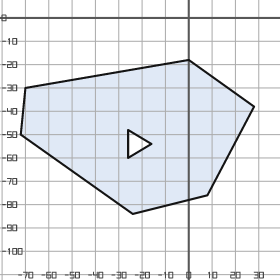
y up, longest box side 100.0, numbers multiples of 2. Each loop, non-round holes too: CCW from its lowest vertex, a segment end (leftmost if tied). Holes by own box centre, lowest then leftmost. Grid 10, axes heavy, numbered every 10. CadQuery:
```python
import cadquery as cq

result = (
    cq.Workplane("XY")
    .moveTo(-24.0, -84.0)
    .lineTo(8.0, -76.0)
    .lineTo(28.0, -38.0)
    .lineTo(0.0, -18.0)
    .lineTo(-70.0, -30.0)
    .lineTo(-72.0, -50.0)
    .close()
    .moveTo(-26.0, -60.0)
    .lineTo(-16.0, -54.0)
    .lineTo(-26.0, -48.0)
    .close()
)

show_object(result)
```